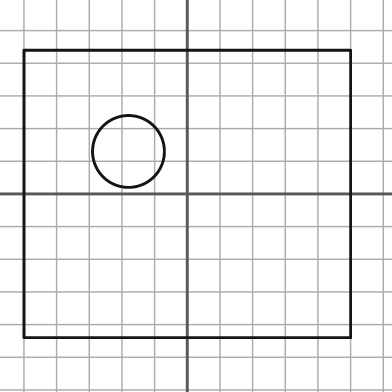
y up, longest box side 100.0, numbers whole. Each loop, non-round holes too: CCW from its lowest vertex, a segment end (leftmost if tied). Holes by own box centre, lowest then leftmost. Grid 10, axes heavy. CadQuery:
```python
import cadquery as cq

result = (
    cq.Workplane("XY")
    .moveTo(-50.0, -44.0)
    .lineTo(50.0, -44.0)
    .lineTo(50.0, 44.0)
    .lineTo(-50.0, 44.0)
    .close()
    .moveTo(-18.0, 13.0)
    .circle(11.0)
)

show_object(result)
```